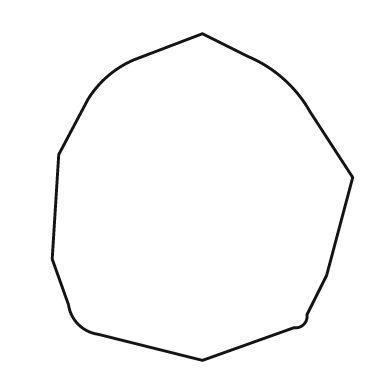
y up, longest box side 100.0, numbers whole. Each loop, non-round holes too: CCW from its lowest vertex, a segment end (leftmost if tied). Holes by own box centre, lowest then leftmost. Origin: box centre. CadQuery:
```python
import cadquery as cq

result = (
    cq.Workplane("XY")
    .moveTo(0.0, -50.0)
    .lineTo(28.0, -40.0)
    .threePointArc((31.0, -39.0), (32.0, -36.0))
    .lineTo(38.0, -24.0)
    .lineTo(46.0, 6.0)
    .lineTo(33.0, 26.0)
    .threePointArc((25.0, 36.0), (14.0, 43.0))
    .lineTo(0.0, 50.0)
    .lineTo(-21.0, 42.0)
    .threePointArc((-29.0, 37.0), (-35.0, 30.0))
    .lineTo(-44.0, 13.0)
    .lineTo(-46.0, -19.0)
    .lineTo(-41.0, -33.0)
    .threePointArc((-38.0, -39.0), (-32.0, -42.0))
    .close()
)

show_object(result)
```